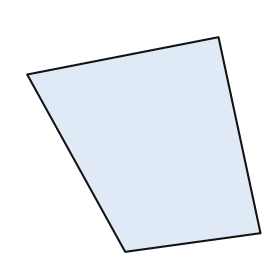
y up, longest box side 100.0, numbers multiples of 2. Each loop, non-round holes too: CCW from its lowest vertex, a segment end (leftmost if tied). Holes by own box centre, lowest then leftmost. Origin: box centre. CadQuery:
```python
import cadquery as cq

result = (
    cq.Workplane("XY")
    .moveTo(-8.0, -46.0)
    .lineTo(50.0, -38.0)
    .lineTo(32.0, 46.0)
    .lineTo(-50.0, 30.0)
    .close()
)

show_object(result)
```